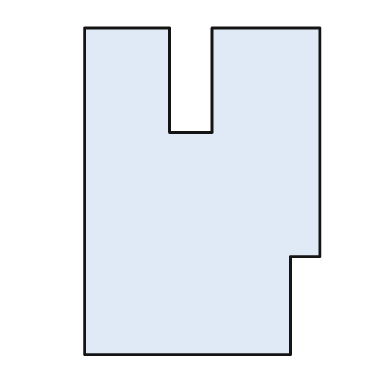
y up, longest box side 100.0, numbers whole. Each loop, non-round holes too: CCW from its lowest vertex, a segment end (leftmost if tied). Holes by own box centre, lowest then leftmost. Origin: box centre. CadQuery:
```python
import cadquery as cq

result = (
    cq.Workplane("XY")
    .moveTo(-36.0, -50.0)
    .lineTo(27.0, -50.0)
    .lineTo(27.0, -20.0)
    .lineTo(36.0, -20.0)
    .lineTo(36.0, 50.0)
    .lineTo(3.0, 50.0)
    .lineTo(3.0, 18.0)
    .lineTo(-10.0, 18.0)
    .lineTo(-10.0, 50.0)
    .lineTo(-36.0, 50.0)
    .close()
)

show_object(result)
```